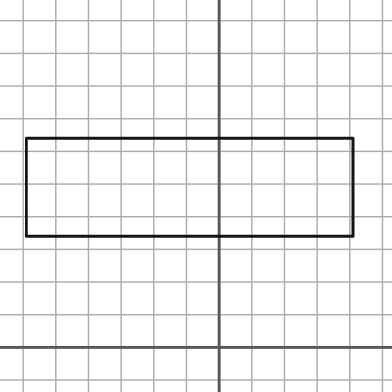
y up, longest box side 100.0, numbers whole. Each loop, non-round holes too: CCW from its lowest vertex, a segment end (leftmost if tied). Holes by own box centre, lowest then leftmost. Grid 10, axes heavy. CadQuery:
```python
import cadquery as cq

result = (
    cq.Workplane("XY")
    .moveTo(-59.0, 34.0)
    .lineTo(41.0, 34.0)
    .lineTo(41.0, 64.0)
    .lineTo(-59.0, 64.0)
    .close()
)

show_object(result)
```